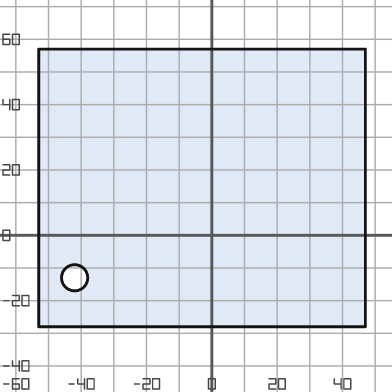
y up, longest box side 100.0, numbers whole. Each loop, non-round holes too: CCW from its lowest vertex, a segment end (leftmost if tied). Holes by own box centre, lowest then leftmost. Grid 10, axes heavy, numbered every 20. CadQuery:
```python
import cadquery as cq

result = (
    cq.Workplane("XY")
    .moveTo(-53.0, -28.0)
    .lineTo(47.0, -28.0)
    .lineTo(47.0, 57.0)
    .lineTo(-53.0, 57.0)
    .close()
    .moveTo(-42.0, -13.0)
    .circle(4.0)
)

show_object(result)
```